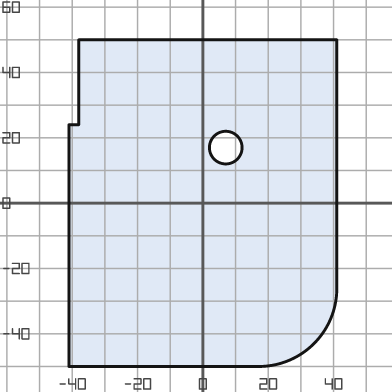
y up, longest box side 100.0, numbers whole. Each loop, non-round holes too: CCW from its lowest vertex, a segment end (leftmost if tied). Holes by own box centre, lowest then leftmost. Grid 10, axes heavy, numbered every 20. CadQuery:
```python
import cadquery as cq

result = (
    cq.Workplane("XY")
    .moveTo(-41.0, -50.0)
    .lineTo(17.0, -50.0)
    .threePointArc((34.0, -43.0), (41.0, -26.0))
    .lineTo(41.0, 50.0)
    .lineTo(-38.0, 50.0)
    .lineTo(-38.0, 24.0)
    .lineTo(-41.0, 24.0)
    .close()
    .moveTo(7.0, 17.0)
    .circle(5.0)
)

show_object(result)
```